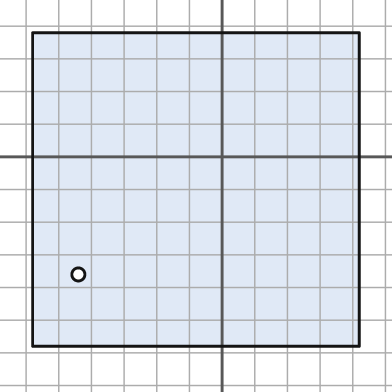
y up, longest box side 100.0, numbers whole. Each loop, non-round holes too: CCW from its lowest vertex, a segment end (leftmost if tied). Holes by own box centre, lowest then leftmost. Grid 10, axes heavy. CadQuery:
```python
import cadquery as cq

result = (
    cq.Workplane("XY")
    .moveTo(-58.0, -58.0)
    .lineTo(42.0, -58.0)
    .lineTo(42.0, 38.0)
    .lineTo(-58.0, 38.0)
    .close()
    .moveTo(-44.0, -36.0)
    .circle(2.0)
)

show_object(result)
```